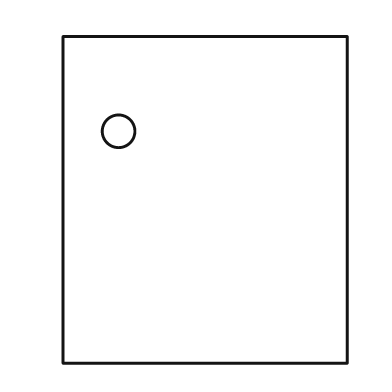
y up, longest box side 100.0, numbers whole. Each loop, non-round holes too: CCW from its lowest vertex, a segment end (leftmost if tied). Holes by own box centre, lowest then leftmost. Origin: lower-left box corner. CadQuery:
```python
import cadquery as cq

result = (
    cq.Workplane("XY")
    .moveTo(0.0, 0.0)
    .lineTo(87.0, 0.0)
    .lineTo(87.0, 100.0)
    .lineTo(0.0, 100.0)
    .close()
    .moveTo(17.0, 71.0)
    .circle(5.0)
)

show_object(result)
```